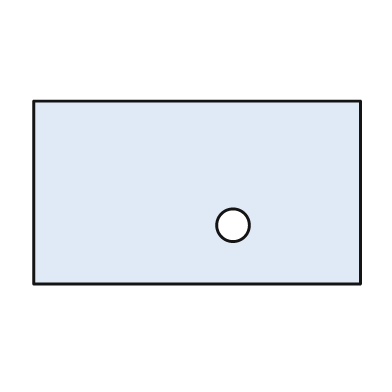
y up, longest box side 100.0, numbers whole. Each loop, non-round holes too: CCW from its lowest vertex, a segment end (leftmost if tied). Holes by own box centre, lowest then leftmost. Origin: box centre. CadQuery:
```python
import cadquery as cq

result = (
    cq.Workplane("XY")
    .moveTo(-50.0, -28.0)
    .lineTo(50.0, -28.0)
    .lineTo(50.0, 28.0)
    .lineTo(-50.0, 28.0)
    .close()
    .moveTo(11.0, -10.0)
    .circle(5.0)
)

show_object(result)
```